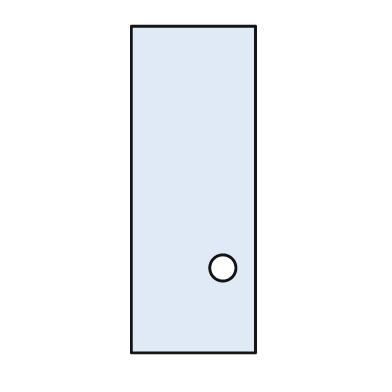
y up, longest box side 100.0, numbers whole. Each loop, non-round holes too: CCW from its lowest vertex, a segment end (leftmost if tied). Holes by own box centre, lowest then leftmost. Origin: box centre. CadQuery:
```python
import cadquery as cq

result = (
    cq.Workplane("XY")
    .moveTo(-19.0, -50.0)
    .lineTo(19.0, -50.0)
    .lineTo(19.0, 50.0)
    .lineTo(-19.0, 50.0)
    .close()
    .moveTo(9.0, -24.0)
    .circle(4.0)
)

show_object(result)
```